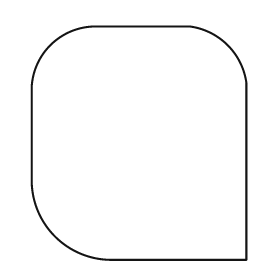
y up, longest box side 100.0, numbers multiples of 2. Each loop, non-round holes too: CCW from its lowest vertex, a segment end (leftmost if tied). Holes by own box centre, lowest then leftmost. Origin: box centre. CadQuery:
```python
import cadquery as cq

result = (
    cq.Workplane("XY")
    .moveTo(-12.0, -50.0)
    .lineTo(46.0, -50.0)
    .lineTo(46.0, 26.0)
    .threePointArc((38.0, 42.0), (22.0, 50.0))
    .lineTo(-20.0, 50.0)
    .threePointArc((-38.0, 42.0), (-46.0, 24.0))
    .lineTo(-46.0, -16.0)
    .threePointArc((-36.0, -40.0), (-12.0, -50.0))
    .close()
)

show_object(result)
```